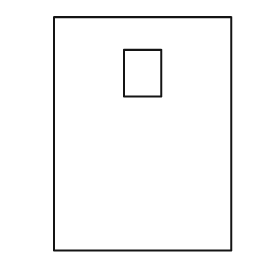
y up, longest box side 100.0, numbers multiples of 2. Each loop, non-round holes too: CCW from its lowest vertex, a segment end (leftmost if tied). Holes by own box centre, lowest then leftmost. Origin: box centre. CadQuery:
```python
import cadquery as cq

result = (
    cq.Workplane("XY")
    .moveTo(-38.0, -50.0)
    .lineTo(38.0, -50.0)
    .lineTo(38.0, 50.0)
    .lineTo(-38.0, 50.0)
    .close()
    .moveTo(-8.0, 16.0)
    .lineTo(8.0, 16.0)
    .lineTo(8.0, 36.0)
    .lineTo(-8.0, 36.0)
    .close()
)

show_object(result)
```